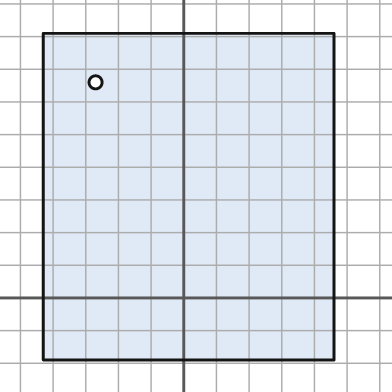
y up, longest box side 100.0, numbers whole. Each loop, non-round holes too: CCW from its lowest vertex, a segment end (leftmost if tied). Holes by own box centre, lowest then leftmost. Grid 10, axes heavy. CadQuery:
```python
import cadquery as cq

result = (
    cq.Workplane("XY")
    .moveTo(-43.0, -19.0)
    .lineTo(46.0, -19.0)
    .lineTo(46.0, 81.0)
    .lineTo(-43.0, 81.0)
    .close()
    .moveTo(-27.0, 66.0)
    .circle(2.0)
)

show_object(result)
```